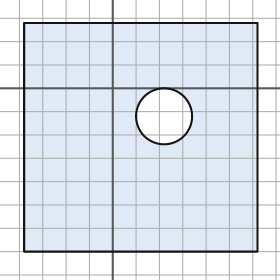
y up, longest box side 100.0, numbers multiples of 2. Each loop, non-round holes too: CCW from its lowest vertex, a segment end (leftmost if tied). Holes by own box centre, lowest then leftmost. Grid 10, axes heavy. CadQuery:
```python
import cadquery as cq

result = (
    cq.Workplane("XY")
    .moveTo(-38.0, -70.0)
    .lineTo(62.0, -70.0)
    .lineTo(62.0, 28.0)
    .lineTo(-38.0, 28.0)
    .close()
    .moveTo(22.0, -12.0)
    .circle(12.0)
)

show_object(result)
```